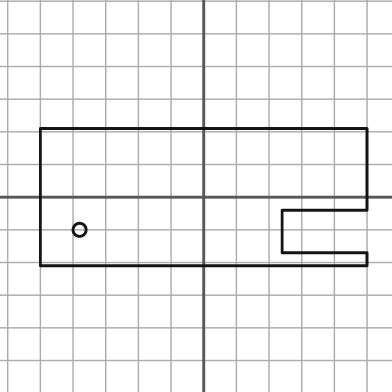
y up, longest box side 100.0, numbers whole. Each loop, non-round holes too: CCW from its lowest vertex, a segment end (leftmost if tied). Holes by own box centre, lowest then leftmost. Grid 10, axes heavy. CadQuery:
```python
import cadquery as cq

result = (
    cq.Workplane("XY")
    .moveTo(-50.0, -21.0)
    .lineTo(50.0, -21.0)
    .lineTo(50.0, -17.0)
    .lineTo(24.0, -17.0)
    .lineTo(24.0, -4.0)
    .lineTo(50.0, -4.0)
    .lineTo(50.0, 21.0)
    .lineTo(-50.0, 21.0)
    .close()
    .moveTo(-38.0, -10.0)
    .circle(2.0)
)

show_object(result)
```